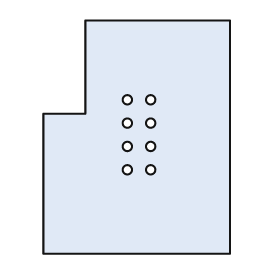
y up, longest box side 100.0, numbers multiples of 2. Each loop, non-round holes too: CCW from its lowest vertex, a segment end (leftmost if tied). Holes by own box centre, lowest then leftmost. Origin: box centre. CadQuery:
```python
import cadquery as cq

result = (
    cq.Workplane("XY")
    .moveTo(-40.0, -50.0)
    .lineTo(40.0, -50.0)
    .lineTo(40.0, 50.0)
    .lineTo(-22.0, 50.0)
    .lineTo(-22.0, 10.0)
    .lineTo(-40.0, 10.0)
    .close()
    .moveTo(-4.0, -14.0)
    .circle(2.0)
    .moveTo(6.0, -14.0)
    .circle(2.0)
    .moveTo(-4.0, -4.0)
    .circle(2.0)
    .moveTo(6.0, -4.0)
    .circle(2.0)
    .moveTo(-4.0, 6.0)
    .circle(2.0)
    .moveTo(6.0, 6.0)
    .circle(2.0)
    .moveTo(-4.0, 16.0)
    .circle(2.0)
    .moveTo(6.0, 16.0)
    .circle(2.0)
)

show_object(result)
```